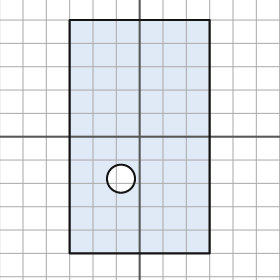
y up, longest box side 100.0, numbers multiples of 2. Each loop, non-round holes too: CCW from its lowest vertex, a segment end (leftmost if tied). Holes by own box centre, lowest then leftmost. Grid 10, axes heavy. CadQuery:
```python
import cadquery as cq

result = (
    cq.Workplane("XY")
    .moveTo(-30.0, -50.0)
    .lineTo(30.0, -50.0)
    .lineTo(30.0, 50.0)
    .lineTo(-30.0, 50.0)
    .close()
    .moveTo(-8.0, -18.0)
    .circle(6.0)
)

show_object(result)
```